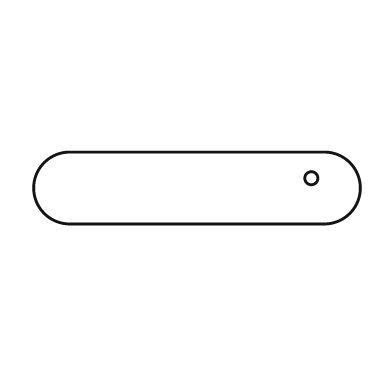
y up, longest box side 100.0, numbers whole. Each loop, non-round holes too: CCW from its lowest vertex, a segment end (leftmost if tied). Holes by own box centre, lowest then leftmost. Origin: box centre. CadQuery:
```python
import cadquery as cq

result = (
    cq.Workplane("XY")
    .moveTo(-39.0, -11.0)
    .lineTo(39.0, -11.0)
    .threePointArc((50.0, 0.0), (39.0, 11.0))
    .lineTo(-39.0, 11.0)
    .threePointArc((-50.0, 0.0), (-39.0, -11.0))
    .close()
    .moveTo(35.0, 3.0)
    .circle(2.0)
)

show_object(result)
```